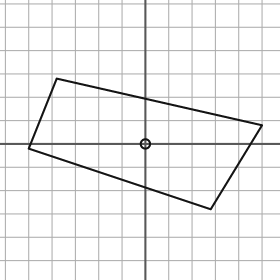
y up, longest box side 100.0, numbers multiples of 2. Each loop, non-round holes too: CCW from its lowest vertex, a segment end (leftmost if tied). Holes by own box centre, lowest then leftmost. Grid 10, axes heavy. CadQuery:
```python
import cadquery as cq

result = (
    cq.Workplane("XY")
    .moveTo(28.0, -28.0)
    .lineTo(50.0, 8.0)
    .lineTo(-38.0, 28.0)
    .lineTo(-50.0, -2.0)
    .close()
    .moveTo(0.0, 0.0)
    .circle(2.0)
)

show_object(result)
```